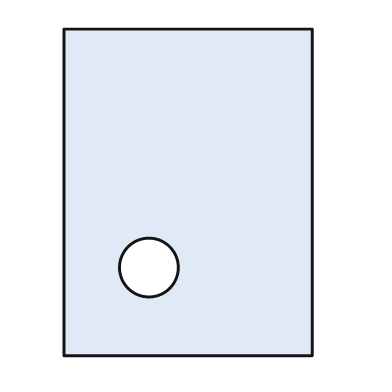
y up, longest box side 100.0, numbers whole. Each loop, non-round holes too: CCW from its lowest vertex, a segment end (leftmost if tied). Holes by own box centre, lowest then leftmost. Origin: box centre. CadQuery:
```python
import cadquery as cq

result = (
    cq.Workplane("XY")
    .moveTo(-38.0, -50.0)
    .lineTo(38.0, -50.0)
    .lineTo(38.0, 50.0)
    .lineTo(-38.0, 50.0)
    .close()
    .moveTo(-12.0, -23.0)
    .circle(9.0)
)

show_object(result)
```